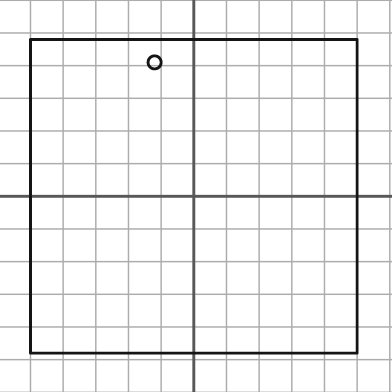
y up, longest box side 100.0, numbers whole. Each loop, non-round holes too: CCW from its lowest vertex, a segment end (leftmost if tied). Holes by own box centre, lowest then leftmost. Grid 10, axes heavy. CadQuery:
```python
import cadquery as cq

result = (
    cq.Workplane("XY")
    .moveTo(-50.0, -48.0)
    .lineTo(50.0, -48.0)
    .lineTo(50.0, 48.0)
    .lineTo(-50.0, 48.0)
    .close()
    .moveTo(-12.0, 41.0)
    .circle(2.0)
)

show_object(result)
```